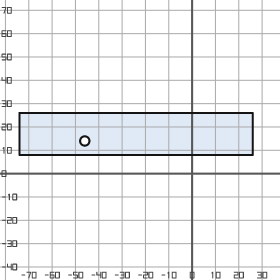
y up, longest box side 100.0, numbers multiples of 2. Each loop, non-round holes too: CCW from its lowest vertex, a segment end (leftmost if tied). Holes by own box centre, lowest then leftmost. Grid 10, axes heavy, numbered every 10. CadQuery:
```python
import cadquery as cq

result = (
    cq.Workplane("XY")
    .moveTo(-74.0, 8.0)
    .lineTo(26.0, 8.0)
    .lineTo(26.0, 26.0)
    .lineTo(-74.0, 26.0)
    .close()
    .moveTo(-46.0, 14.0)
    .circle(2.0)
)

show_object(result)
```